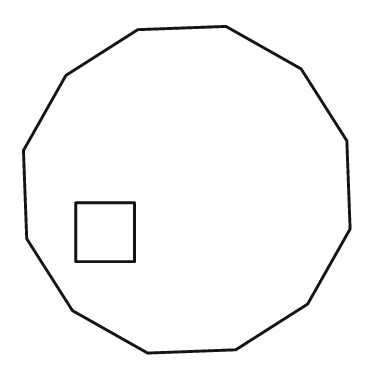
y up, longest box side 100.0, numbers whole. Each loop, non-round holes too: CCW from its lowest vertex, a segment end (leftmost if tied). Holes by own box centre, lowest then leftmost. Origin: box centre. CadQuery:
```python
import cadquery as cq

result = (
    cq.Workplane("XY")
    .moveTo(-12.0, -50.0)
    .lineTo(15.0, -49.0)
    .lineTo(37.0, -35.0)
    .lineTo(50.0, -12.0)
    .lineTo(49.0, 15.0)
    .lineTo(35.0, 37.0)
    .lineTo(12.0, 50.0)
    .lineTo(-15.0, 49.0)
    .lineTo(-37.0, 35.0)
    .lineTo(-50.0, 12.0)
    .lineTo(-49.0, -15.0)
    .lineTo(-35.0, -37.0)
    .close()
    .moveTo(-34.0, -22.0)
    .lineTo(-16.0, -22.0)
    .lineTo(-16.0, -4.0)
    .lineTo(-34.0, -4.0)
    .close()
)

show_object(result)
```